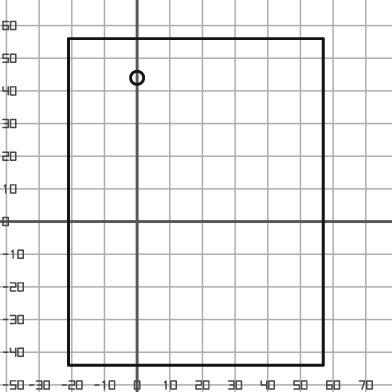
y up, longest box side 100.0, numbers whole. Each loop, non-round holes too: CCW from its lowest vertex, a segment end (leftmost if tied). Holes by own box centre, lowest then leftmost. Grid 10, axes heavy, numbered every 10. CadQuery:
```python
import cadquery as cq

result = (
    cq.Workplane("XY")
    .moveTo(-21.0, -44.0)
    .lineTo(57.0, -44.0)
    .lineTo(57.0, 56.0)
    .lineTo(-21.0, 56.0)
    .close()
    .moveTo(0.0, 44.0)
    .circle(2.0)
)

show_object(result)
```